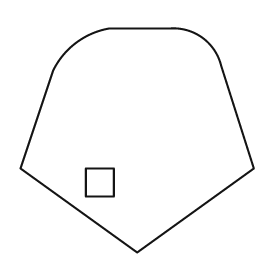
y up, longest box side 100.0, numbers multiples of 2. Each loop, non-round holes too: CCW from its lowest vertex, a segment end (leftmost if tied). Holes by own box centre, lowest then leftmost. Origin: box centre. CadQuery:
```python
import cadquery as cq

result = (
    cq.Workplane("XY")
    .moveTo(0.0, -48.0)
    .lineTo(50.0, -12.0)
    .lineTo(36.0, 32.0)
    .threePointArc((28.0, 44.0), (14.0, 48.0))
    .lineTo(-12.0, 48.0)
    .threePointArc((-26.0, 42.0), (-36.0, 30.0))
    .lineTo(-50.0, -12.0)
    .close()
    .moveTo(-22.0, -24.0)
    .lineTo(-10.0, -24.0)
    .lineTo(-10.0, -12.0)
    .lineTo(-22.0, -12.0)
    .close()
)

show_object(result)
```